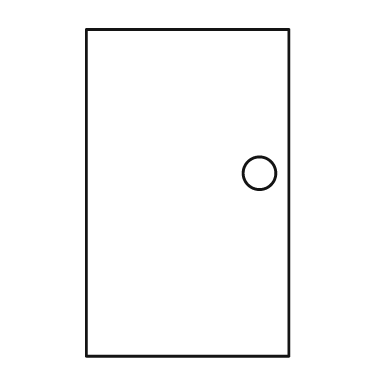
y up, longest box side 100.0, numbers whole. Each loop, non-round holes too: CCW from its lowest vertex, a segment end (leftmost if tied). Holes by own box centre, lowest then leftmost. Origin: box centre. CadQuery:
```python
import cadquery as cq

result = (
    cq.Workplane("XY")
    .moveTo(-31.0, -50.0)
    .lineTo(31.0, -50.0)
    .lineTo(31.0, 50.0)
    .lineTo(-31.0, 50.0)
    .close()
    .moveTo(22.0, 6.0)
    .circle(5.0)
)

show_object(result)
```